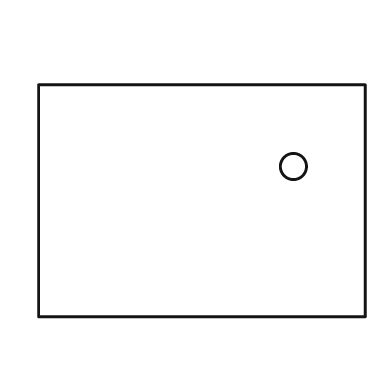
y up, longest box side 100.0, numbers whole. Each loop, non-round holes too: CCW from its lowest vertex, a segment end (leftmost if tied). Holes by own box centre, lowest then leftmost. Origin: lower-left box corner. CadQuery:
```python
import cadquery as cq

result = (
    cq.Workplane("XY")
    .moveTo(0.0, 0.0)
    .lineTo(100.0, 0.0)
    .lineTo(100.0, 71.0)
    .lineTo(0.0, 71.0)
    .close()
    .moveTo(78.0, 46.0)
    .circle(4.0)
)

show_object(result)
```